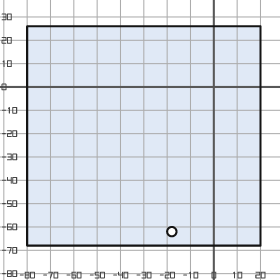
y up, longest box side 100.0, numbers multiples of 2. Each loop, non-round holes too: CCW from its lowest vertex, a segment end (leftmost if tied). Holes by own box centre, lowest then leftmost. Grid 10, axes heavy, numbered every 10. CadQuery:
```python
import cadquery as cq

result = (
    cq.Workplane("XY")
    .moveTo(-80.0, -68.0)
    .lineTo(20.0, -68.0)
    .lineTo(20.0, 26.0)
    .lineTo(-80.0, 26.0)
    .close()
    .moveTo(-18.0, -62.0)
    .circle(2.0)
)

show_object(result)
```